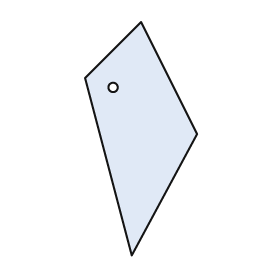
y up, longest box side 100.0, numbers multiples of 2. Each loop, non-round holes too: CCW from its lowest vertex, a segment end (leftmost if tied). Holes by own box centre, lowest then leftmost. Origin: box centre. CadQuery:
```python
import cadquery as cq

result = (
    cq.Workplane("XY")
    .moveTo(-4.0, -50.0)
    .lineTo(24.0, 2.0)
    .lineTo(0.0, 50.0)
    .lineTo(-24.0, 26.0)
    .close()
    .moveTo(-12.0, 22.0)
    .circle(2.0)
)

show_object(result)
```